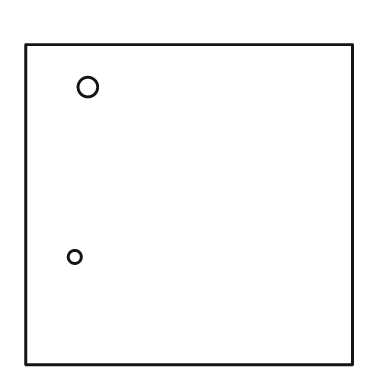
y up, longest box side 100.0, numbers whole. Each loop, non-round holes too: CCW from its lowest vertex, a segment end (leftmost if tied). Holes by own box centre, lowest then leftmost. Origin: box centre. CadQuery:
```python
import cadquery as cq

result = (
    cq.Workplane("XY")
    .moveTo(-50.0, -49.0)
    .lineTo(50.0, -49.0)
    .lineTo(50.0, 49.0)
    .lineTo(-50.0, 49.0)
    .close()
    .moveTo(-35.0, -16.0)
    .circle(2.0)
    .moveTo(-31.0, 36.0)
    .circle(3.0)
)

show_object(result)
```